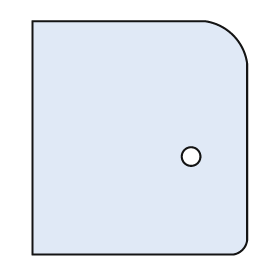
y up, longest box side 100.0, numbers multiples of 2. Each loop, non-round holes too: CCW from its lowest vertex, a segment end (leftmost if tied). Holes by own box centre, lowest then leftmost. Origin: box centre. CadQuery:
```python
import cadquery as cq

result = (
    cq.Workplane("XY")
    .moveTo(-46.0, -50.0)
    .lineTo(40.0, -50.0)
    .threePointArc((44.0, -48.0), (46.0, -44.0))
    .lineTo(46.0, 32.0)
    .threePointArc((40.0, 44.0), (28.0, 50.0))
    .lineTo(-46.0, 50.0)
    .close()
    .moveTo(22.0, -8.0)
    .circle(4.0)
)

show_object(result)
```